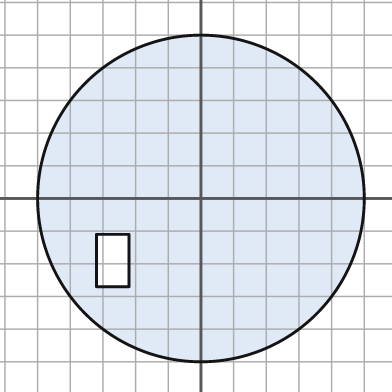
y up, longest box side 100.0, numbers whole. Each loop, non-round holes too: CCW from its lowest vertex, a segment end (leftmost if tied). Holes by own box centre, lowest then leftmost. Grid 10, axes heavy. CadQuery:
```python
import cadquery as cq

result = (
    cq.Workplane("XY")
    .moveTo(0.0, 0.0)
    .circle(50.0)
    .moveTo(-32.0, -27.0)
    .lineTo(-22.0, -27.0)
    .lineTo(-22.0, -11.0)
    .lineTo(-32.0, -11.0)
    .close()
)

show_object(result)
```